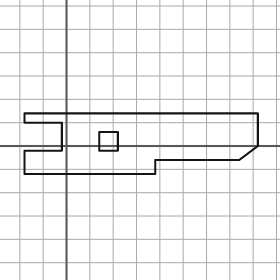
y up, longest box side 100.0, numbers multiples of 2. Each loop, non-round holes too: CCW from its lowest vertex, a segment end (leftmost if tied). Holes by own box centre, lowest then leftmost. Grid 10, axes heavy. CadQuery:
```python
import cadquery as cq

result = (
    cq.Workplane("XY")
    .moveTo(-18.0, -12.0)
    .lineTo(38.0, -12.0)
    .lineTo(38.0, -6.0)
    .lineTo(74.0, -6.0)
    .lineTo(82.0, 0.0)
    .lineTo(82.0, 14.0)
    .lineTo(-18.0, 14.0)
    .lineTo(-18.0, 10.0)
    .lineTo(-2.0, 10.0)
    .lineTo(-2.0, -2.0)
    .lineTo(-18.0, -2.0)
    .close()
    .moveTo(14.0, -2.0)
    .lineTo(22.0, -2.0)
    .lineTo(22.0, 6.0)
    .lineTo(14.0, 6.0)
    .close()
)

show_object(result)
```